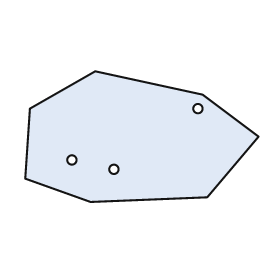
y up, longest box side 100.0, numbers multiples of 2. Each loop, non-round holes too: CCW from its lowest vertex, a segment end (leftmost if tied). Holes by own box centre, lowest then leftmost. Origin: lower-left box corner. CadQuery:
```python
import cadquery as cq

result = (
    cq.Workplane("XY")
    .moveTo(28.0, 0.0)
    .lineTo(78.0, 2.0)
    .lineTo(100.0, 28.0)
    .lineTo(76.0, 46.0)
    .lineTo(30.0, 56.0)
    .lineTo(2.0, 40.0)
    .lineTo(0.0, 10.0)
    .close()
    .moveTo(38.0, 14.0)
    .circle(2.0)
    .moveTo(20.0, 18.0)
    .circle(2.0)
    .moveTo(74.0, 40.0)
    .circle(2.0)
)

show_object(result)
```